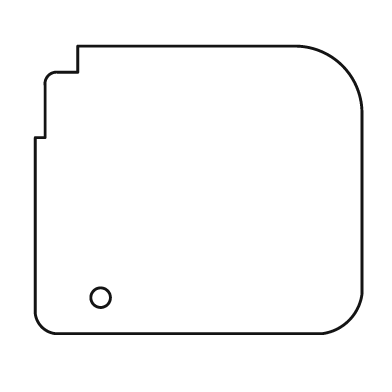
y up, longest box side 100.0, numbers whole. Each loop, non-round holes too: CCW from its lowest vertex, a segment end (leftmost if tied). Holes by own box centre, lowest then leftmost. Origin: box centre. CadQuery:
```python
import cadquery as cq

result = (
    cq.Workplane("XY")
    .moveTo(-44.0, -44.0)
    .lineTo(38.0, -44.0)
    .threePointArc((46.0, -40.0), (50.0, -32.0))
    .lineTo(50.0, 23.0)
    .threePointArc((44.0, 38.0), (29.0, 44.0))
    .lineTo(-37.0, 44.0)
    .lineTo(-37.0, 36.0)
    .lineTo(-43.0, 36.0)
    .threePointArc((-46.0, 35.0), (-47.0, 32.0))
    .lineTo(-47.0, 16.0)
    .lineTo(-50.0, 16.0)
    .lineTo(-50.0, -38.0)
    .threePointArc((-48.0, -42.0), (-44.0, -44.0))
    .close()
    .moveTo(-30.0, -33.0)
    .circle(3.0)
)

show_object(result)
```